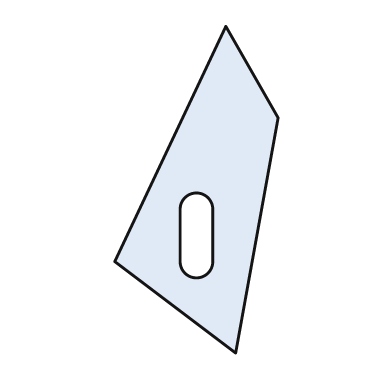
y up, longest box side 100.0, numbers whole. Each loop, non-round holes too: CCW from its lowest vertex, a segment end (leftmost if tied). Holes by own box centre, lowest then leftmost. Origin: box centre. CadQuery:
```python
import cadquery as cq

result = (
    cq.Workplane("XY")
    .moveTo(12.0, -50.0)
    .lineTo(25.0, 22.0)
    .lineTo(9.0, 50.0)
    .lineTo(-25.0, -22.0)
    .close()
    .moveTo(-5.0, -22.0)
    .threePointArc((0.0, -27.0), (5.0, -22.0))
    .lineTo(5.0, -6.0)
    .threePointArc((0.0, -1.0), (-5.0, -6.0))
    .close()
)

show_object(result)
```